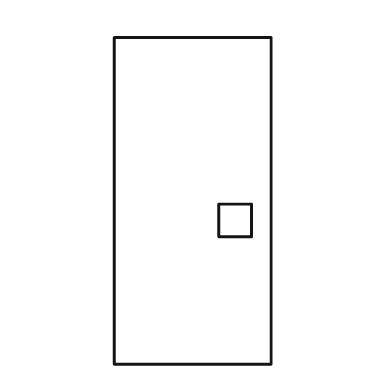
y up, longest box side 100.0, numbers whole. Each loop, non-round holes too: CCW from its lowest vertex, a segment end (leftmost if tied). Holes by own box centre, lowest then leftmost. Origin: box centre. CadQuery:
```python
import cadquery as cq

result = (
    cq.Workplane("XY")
    .moveTo(-24.0, -50.0)
    .lineTo(24.0, -50.0)
    .lineTo(24.0, 50.0)
    .lineTo(-24.0, 50.0)
    .close()
    .moveTo(8.0, -11.0)
    .lineTo(18.0, -11.0)
    .lineTo(18.0, -1.0)
    .lineTo(8.0, -1.0)
    .close()
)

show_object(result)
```